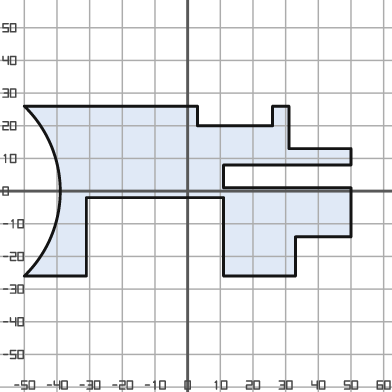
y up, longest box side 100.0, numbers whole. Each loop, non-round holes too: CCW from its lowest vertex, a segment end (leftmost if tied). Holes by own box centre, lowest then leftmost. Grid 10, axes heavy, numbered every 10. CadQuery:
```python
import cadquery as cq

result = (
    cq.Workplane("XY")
    .moveTo(-50.0, -26.0)
    .lineTo(-31.0, -26.0)
    .lineTo(-31.0, -2.0)
    .lineTo(11.0, -2.0)
    .lineTo(11.0, -26.0)
    .lineTo(33.0, -26.0)
    .lineTo(33.0, -14.0)
    .lineTo(50.0, -14.0)
    .lineTo(50.0, 1.0)
    .lineTo(11.0, 1.0)
    .lineTo(11.0, 8.0)
    .lineTo(50.0, 8.0)
    .lineTo(50.0, 13.0)
    .lineTo(31.0, 13.0)
    .lineTo(31.0, 26.0)
    .lineTo(26.0, 26.0)
    .lineTo(26.0, 20.0)
    .lineTo(3.0, 20.0)
    .lineTo(3.0, 26.0)
    .lineTo(-50.0, 26.0)
    .threePointArc((-39.0, 0.0), (-50.0, -26.0))
    .close()
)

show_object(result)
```